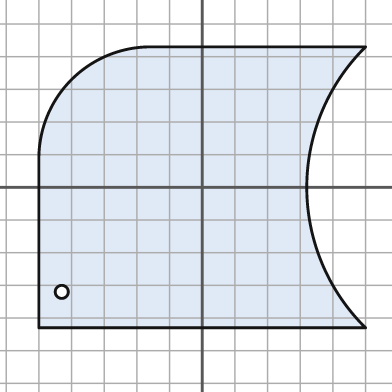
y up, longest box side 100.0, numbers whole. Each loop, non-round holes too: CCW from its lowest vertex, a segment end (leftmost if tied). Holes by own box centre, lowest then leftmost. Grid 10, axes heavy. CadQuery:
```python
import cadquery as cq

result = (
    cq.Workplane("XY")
    .moveTo(-50.0, -43.0)
    .lineTo(50.0, -43.0)
    .threePointArc((32.0, 0.0), (50.0, 43.0))
    .lineTo(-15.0, 43.0)
    .threePointArc((-40.0, 33.0), (-50.0, 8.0))
    .close()
    .moveTo(-43.0, -32.0)
    .circle(2.0)
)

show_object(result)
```